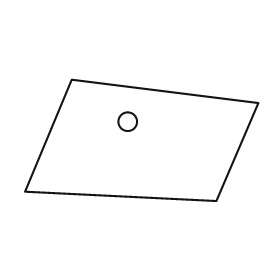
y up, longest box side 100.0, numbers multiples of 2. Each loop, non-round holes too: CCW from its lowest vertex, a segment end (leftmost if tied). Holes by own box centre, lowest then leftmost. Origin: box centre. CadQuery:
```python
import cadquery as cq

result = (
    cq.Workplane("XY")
    .moveTo(32.0, -26.0)
    .lineTo(50.0, 16.0)
    .lineTo(-30.0, 26.0)
    .lineTo(-50.0, -22.0)
    .close()
    .moveTo(-6.0, 8.0)
    .circle(4.0)
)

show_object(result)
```